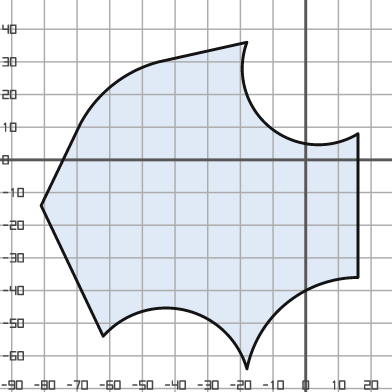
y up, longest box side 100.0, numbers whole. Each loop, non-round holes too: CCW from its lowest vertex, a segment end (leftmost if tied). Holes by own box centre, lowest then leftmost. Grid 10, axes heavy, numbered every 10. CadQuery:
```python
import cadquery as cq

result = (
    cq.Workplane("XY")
    .moveTo(-18.0, -64.0)
    .threePointArc((-6.0, -44.0), (16.0, -36.0))
    .lineTo(16.0, 8.0)
    .threePointArc((-11.0, 10.0), (-18.0, 36.0))
    .lineTo(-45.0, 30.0)
    .threePointArc((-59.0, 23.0), (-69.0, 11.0))
    .lineTo(-81.0, -14.0)
    .lineTo(-62.0, -54.0)
    .threePointArc((-37.0, -46.0), (-18.0, -64.0))
    .close()
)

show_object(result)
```